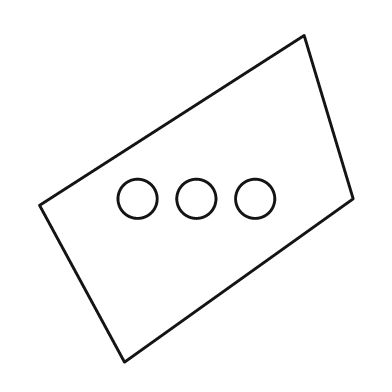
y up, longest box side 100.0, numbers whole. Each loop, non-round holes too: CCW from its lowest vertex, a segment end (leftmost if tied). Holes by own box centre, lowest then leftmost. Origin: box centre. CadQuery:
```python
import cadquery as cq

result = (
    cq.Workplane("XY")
    .moveTo(-22.0, -50.0)
    .lineTo(48.0, 0.0)
    .lineTo(33.0, 50.0)
    .lineTo(-48.0, -2.0)
    .close()
    .moveTo(-18.0, 0.0)
    .circle(6.0)
    .moveTo(0.0, 0.0)
    .circle(6.0)
    .moveTo(18.0, 0.0)
    .circle(6.0)
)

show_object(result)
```